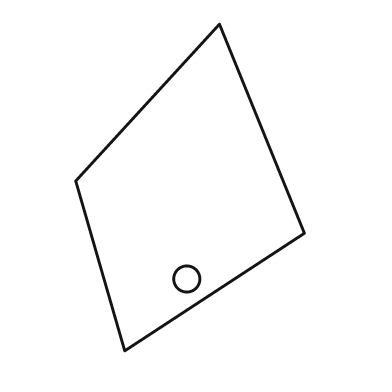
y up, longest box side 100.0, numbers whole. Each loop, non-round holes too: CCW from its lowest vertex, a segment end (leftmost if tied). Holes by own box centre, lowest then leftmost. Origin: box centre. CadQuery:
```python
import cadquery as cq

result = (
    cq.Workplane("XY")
    .moveTo(-20.0, -50.0)
    .lineTo(35.0, -14.0)
    .lineTo(9.0, 50.0)
    .lineTo(-35.0, 2.0)
    .close()
    .moveTo(-1.0, -28.0)
    .circle(4.0)
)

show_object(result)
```